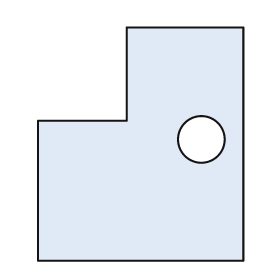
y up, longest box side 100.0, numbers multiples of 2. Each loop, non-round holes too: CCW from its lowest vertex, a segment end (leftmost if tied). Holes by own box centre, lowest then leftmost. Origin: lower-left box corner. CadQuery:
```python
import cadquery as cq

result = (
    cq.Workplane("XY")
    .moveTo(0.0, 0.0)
    .lineTo(88.0, 0.0)
    .lineTo(88.0, 100.0)
    .lineTo(38.0, 100.0)
    .lineTo(38.0, 60.0)
    .lineTo(0.0, 60.0)
    .close()
    .moveTo(70.0, 52.0)
    .circle(10.0)
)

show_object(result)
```